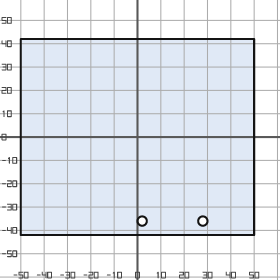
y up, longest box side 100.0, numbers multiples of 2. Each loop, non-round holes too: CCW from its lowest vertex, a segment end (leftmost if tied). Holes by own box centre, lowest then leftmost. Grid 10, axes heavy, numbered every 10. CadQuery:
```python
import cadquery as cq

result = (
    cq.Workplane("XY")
    .moveTo(-50.0, -42.0)
    .lineTo(50.0, -42.0)
    .lineTo(50.0, 42.0)
    .lineTo(-50.0, 42.0)
    .close()
    .moveTo(2.0, -36.0)
    .circle(2.0)
    .moveTo(28.0, -36.0)
    .circle(2.0)
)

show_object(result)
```